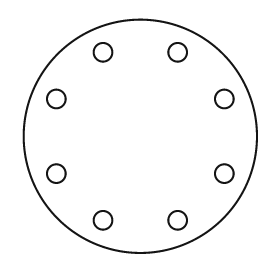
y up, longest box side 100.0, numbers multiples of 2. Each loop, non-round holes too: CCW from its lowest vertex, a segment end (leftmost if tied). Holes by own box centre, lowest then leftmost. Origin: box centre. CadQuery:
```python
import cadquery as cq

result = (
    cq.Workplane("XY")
    .moveTo(0.0, 0.0)
    .circle(50.0)
    .moveTo(-16.0, -36.0)
    .circle(4.0)
    .moveTo(16.0, -36.0)
    .circle(4.0)
    .moveTo(-36.0, -16.0)
    .circle(4.0)
    .moveTo(36.0, -16.0)
    .circle(4.0)
    .moveTo(-36.0, 16.0)
    .circle(4.0)
    .moveTo(36.0, 16.0)
    .circle(4.0)
    .moveTo(-16.0, 36.0)
    .circle(4.0)
    .moveTo(16.0, 36.0)
    .circle(4.0)
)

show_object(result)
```